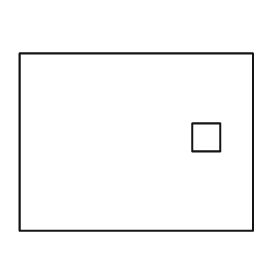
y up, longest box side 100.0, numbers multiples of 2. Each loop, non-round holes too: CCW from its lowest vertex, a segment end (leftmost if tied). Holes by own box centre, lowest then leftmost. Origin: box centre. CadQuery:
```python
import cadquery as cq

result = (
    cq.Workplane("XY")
    .moveTo(-50.0, -38.0)
    .lineTo(50.0, -38.0)
    .lineTo(50.0, 38.0)
    .lineTo(-50.0, 38.0)
    .close()
    .moveTo(24.0, -4.0)
    .lineTo(36.0, -4.0)
    .lineTo(36.0, 8.0)
    .lineTo(24.0, 8.0)
    .close()
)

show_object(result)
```